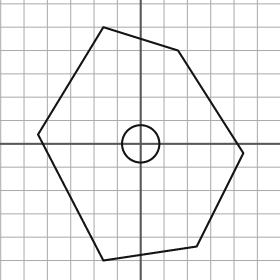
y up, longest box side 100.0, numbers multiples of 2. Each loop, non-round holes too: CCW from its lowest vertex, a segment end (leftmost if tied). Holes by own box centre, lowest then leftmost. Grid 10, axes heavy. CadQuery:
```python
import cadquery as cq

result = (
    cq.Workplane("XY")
    .moveTo(-16.0, -50.0)
    .lineTo(24.0, -44.0)
    .lineTo(44.0, -4.0)
    .lineTo(16.0, 40.0)
    .lineTo(-16.0, 50.0)
    .lineTo(-44.0, 4.0)
    .close()
    .moveTo(0.0, 0.0)
    .circle(8.0)
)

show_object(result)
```